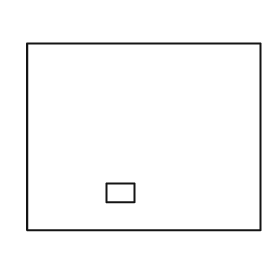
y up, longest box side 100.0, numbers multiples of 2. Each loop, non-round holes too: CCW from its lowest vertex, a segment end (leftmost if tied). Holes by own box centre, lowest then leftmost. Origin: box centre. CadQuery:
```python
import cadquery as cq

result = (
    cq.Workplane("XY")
    .moveTo(-50.0, -40.0)
    .lineTo(50.0, -40.0)
    .lineTo(50.0, 40.0)
    .lineTo(-50.0, 40.0)
    .close()
    .moveTo(-16.0, -28.0)
    .lineTo(-4.0, -28.0)
    .lineTo(-4.0, -20.0)
    .lineTo(-16.0, -20.0)
    .close()
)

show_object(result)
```